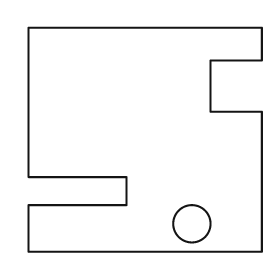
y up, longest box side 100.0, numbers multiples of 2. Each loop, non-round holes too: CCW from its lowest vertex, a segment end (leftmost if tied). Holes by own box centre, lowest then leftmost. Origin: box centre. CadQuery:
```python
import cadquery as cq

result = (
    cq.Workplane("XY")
    .moveTo(-50.0, -48.0)
    .lineTo(50.0, -48.0)
    .lineTo(50.0, 12.0)
    .lineTo(28.0, 12.0)
    .lineTo(28.0, 34.0)
    .lineTo(50.0, 34.0)
    .lineTo(50.0, 48.0)
    .lineTo(-50.0, 48.0)
    .lineTo(-50.0, -16.0)
    .lineTo(-8.0, -16.0)
    .lineTo(-8.0, -28.0)
    .lineTo(-50.0, -28.0)
    .close()
    .moveTo(20.0, -36.0)
    .circle(8.0)
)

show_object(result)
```